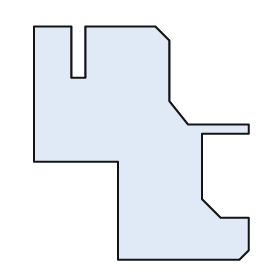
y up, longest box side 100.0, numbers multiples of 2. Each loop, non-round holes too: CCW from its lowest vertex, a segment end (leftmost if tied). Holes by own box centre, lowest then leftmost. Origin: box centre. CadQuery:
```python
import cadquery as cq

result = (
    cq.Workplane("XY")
    .moveTo(-10.0, -50.0)
    .lineTo(42.0, -50.0)
    .lineTo(46.0, -46.0)
    .lineTo(46.0, -32.0)
    .lineTo(34.0, -32.0)
    .lineTo(26.0, -24.0)
    .lineTo(26.0, 4.0)
    .lineTo(46.0, 4.0)
    .lineTo(46.0, 8.0)
    .lineTo(20.0, 8.0)
    .lineTo(12.0, 18.0)
    .lineTo(12.0, 44.0)
    .lineTo(6.0, 50.0)
    .lineTo(-24.0, 50.0)
    .lineTo(-24.0, 28.0)
    .lineTo(-30.0, 28.0)
    .lineTo(-30.0, 50.0)
    .lineTo(-46.0, 50.0)
    .lineTo(-46.0, -8.0)
    .lineTo(-10.0, -8.0)
    .close()
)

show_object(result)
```